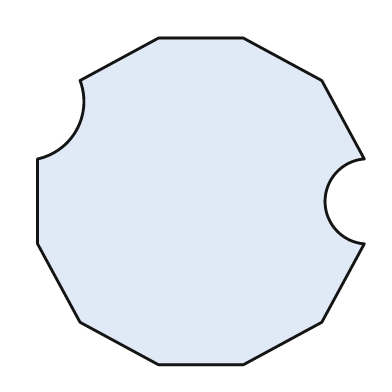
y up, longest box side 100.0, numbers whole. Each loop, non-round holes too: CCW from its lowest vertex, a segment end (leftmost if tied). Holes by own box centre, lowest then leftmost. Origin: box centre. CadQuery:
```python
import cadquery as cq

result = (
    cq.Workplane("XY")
    .moveTo(-13.0, -50.0)
    .lineTo(13.0, -50.0)
    .lineTo(37.0, -37.0)
    .lineTo(50.0, -13.0)
    .threePointArc((38.0, 0.0), (50.0, 13.0))
    .lineTo(37.0, 37.0)
    .lineTo(13.0, 50.0)
    .lineTo(-13.0, 50.0)
    .lineTo(-37.0, 37.0)
    .threePointArc((-38.0, 22.0), (-50.0, 13.0))
    .lineTo(-50.0, -13.0)
    .lineTo(-37.0, -37.0)
    .close()
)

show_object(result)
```